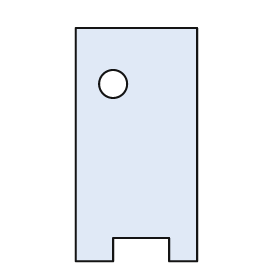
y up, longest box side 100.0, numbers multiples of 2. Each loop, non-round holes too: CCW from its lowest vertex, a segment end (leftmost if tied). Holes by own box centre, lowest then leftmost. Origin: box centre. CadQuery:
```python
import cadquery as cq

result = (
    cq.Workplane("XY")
    .moveTo(-26.0, -50.0)
    .lineTo(-10.0, -50.0)
    .lineTo(-10.0, -40.0)
    .lineTo(14.0, -40.0)
    .lineTo(14.0, -50.0)
    .lineTo(26.0, -50.0)
    .lineTo(26.0, 50.0)
    .lineTo(-26.0, 50.0)
    .close()
    .moveTo(-10.0, 26.0)
    .circle(6.0)
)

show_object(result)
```